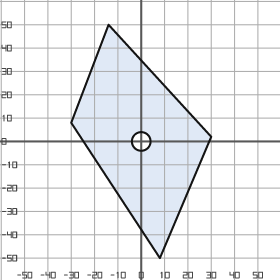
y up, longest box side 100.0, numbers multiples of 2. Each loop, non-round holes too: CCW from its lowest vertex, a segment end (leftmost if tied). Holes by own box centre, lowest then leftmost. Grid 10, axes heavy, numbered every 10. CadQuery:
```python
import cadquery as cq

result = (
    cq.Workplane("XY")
    .moveTo(8.0, -50.0)
    .lineTo(30.0, 2.0)
    .lineTo(-14.0, 50.0)
    .lineTo(-30.0, 8.0)
    .close()
    .moveTo(0.0, 0.0)
    .circle(4.0)
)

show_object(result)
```